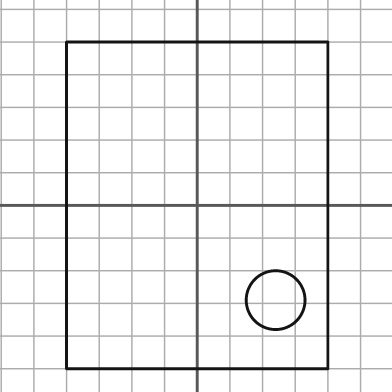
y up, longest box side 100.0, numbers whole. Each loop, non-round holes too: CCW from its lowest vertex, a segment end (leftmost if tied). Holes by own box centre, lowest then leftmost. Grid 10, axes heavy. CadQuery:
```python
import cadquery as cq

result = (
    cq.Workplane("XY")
    .moveTo(-40.0, -50.0)
    .lineTo(40.0, -50.0)
    .lineTo(40.0, 50.0)
    .lineTo(-40.0, 50.0)
    .close()
    .moveTo(24.0, -29.0)
    .circle(9.0)
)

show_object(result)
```